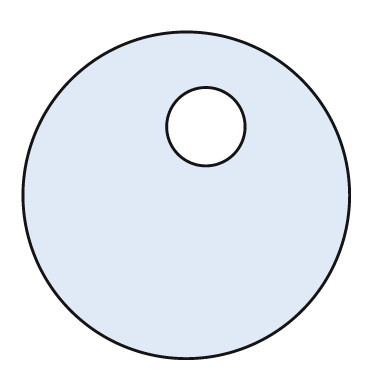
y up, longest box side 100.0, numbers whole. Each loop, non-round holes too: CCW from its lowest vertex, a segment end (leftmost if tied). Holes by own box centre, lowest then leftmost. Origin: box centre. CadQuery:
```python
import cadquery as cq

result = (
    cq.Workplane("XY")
    .moveTo(0.0, 0.0)
    .circle(50.0)
    .moveTo(6.0, 21.0)
    .circle(12.0)
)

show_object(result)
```